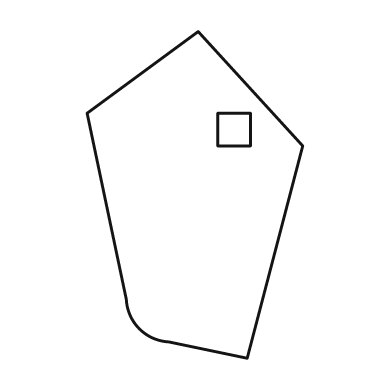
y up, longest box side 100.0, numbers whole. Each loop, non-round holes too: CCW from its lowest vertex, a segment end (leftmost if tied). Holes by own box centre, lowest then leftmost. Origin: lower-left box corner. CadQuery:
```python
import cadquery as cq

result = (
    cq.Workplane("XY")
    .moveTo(49.0, 0.0)
    .lineTo(66.0, 65.0)
    .lineTo(34.0, 100.0)
    .lineTo(0.0, 75.0)
    .lineTo(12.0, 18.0)
    .threePointArc((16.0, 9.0), (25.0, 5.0))
    .close()
    .moveTo(40.0, 65.0)
    .lineTo(50.0, 65.0)
    .lineTo(50.0, 75.0)
    .lineTo(40.0, 75.0)
    .close()
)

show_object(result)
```